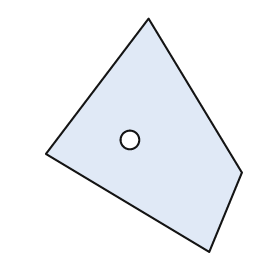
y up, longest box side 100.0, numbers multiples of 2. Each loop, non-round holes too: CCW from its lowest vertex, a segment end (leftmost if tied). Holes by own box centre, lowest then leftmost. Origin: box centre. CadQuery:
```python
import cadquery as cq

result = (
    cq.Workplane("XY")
    .moveTo(28.0, -50.0)
    .lineTo(42.0, -16.0)
    .lineTo(2.0, 50.0)
    .lineTo(-42.0, -8.0)
    .close()
    .moveTo(-6.0, -2.0)
    .circle(4.0)
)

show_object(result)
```